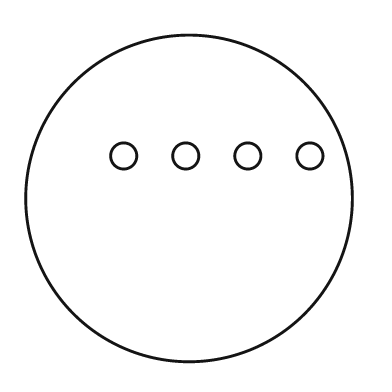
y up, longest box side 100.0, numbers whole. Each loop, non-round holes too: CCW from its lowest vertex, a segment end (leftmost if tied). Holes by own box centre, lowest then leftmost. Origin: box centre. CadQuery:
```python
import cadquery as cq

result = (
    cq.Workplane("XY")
    .moveTo(0.0, 0.0)
    .circle(50.0)
    .moveTo(-20.0, 13.0)
    .circle(4.0)
    .moveTo(-1.0, 13.0)
    .circle(4.0)
    .moveTo(18.0, 13.0)
    .circle(4.0)
    .moveTo(37.0, 13.0)
    .circle(4.0)
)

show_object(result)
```